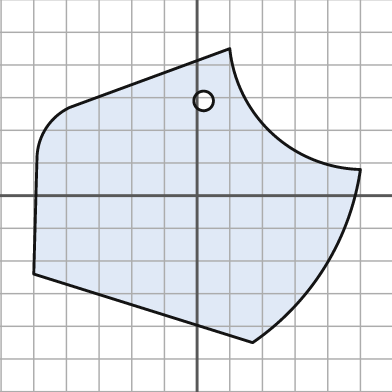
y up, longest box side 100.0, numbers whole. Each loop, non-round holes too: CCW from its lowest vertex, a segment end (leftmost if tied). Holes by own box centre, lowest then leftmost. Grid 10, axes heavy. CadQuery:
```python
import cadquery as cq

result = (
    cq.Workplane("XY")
    .moveTo(17.0, -45.0)
    .threePointArc((39.0, -22.0), (50.0, 8.0))
    .threePointArc((23.0, 19.0), (10.0, 45.0))
    .lineTo(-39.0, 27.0)
    .threePointArc((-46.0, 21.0), (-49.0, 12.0))
    .lineTo(-50.0, -24.0)
    .close()
    .moveTo(2.0, 29.0)
    .circle(3.0)
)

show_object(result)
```